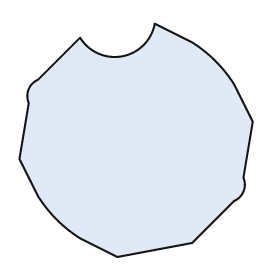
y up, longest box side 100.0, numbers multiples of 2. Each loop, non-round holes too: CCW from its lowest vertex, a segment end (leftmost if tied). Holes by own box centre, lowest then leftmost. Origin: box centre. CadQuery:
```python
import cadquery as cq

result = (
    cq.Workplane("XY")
    .moveTo(-8.0, -50.0)
    .lineTo(24.0, -44.0)
    .lineTo(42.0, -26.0)
    .threePointArc((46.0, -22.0), (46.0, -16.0))
    .lineTo(50.0, 8.0)
    .lineTo(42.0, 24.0)
    .threePointArc((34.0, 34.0), (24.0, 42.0))
    .lineTo(8.0, 50.0)
    .threePointArc((-6.0, 36.0), (-24.0, 44.0))
    .lineTo(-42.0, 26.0)
    .threePointArc((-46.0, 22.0), (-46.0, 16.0))
    .lineTo(-50.0, -8.0)
    .lineTo(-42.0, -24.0)
    .threePointArc((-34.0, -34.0), (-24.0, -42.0))
    .close()
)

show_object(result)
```